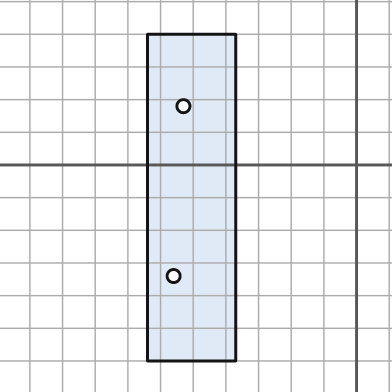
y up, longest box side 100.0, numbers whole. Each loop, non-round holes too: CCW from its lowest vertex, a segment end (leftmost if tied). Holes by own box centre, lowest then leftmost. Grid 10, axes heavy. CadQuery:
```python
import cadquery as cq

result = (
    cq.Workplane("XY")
    .moveTo(-64.0, -60.0)
    .lineTo(-37.0, -60.0)
    .lineTo(-37.0, 40.0)
    .lineTo(-64.0, 40.0)
    .close()
    .moveTo(-56.0, -34.0)
    .circle(2.0)
    .moveTo(-53.0, 18.0)
    .circle(2.0)
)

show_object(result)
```